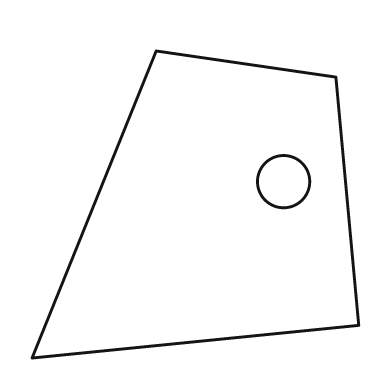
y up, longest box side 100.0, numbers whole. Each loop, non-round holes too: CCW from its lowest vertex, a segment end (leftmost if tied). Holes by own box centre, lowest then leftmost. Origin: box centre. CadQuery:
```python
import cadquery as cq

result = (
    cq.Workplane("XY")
    .moveTo(-50.0, -47.0)
    .lineTo(50.0, -37.0)
    .lineTo(43.0, 39.0)
    .lineTo(-12.0, 47.0)
    .close()
    .moveTo(27.0, 7.0)
    .circle(8.0)
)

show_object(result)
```